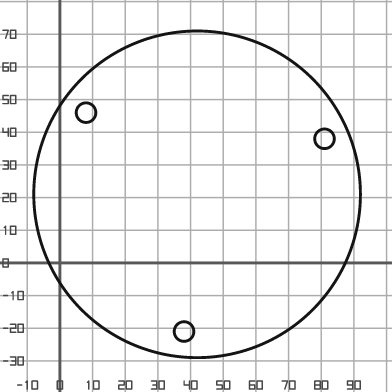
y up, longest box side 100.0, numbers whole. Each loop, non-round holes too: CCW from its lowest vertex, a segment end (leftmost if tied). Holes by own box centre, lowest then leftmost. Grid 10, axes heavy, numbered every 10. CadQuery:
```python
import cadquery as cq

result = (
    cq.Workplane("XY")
    .moveTo(42.0, 21.0)
    .circle(50.0)
    .moveTo(38.0, -21.0)
    .circle(3.0)
    .moveTo(81.0, 38.0)
    .circle(3.0)
    .moveTo(8.0, 46.0)
    .circle(3.0)
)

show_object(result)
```